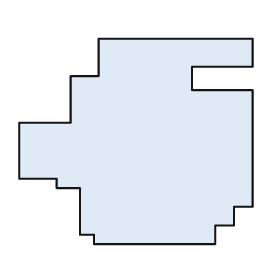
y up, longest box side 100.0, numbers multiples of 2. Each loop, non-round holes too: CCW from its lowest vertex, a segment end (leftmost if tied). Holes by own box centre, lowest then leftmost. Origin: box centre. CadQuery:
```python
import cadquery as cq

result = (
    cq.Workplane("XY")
    .moveTo(-18.0, -44.0)
    .lineTo(34.0, -44.0)
    .lineTo(34.0, -36.0)
    .lineTo(42.0, -36.0)
    .lineTo(42.0, -28.0)
    .lineTo(50.0, -28.0)
    .lineTo(50.0, 22.0)
    .lineTo(24.0, 22.0)
    .lineTo(24.0, 32.0)
    .lineTo(50.0, 32.0)
    .lineTo(50.0, 44.0)
    .lineTo(-16.0, 44.0)
    .lineTo(-16.0, 28.0)
    .lineTo(-28.0, 28.0)
    .lineTo(-28.0, 8.0)
    .lineTo(-50.0, 8.0)
    .lineTo(-50.0, -16.0)
    .lineTo(-34.0, -16.0)
    .lineTo(-34.0, -20.0)
    .lineTo(-24.0, -20.0)
    .lineTo(-24.0, -40.0)
    .lineTo(-18.0, -40.0)
    .close()
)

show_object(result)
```